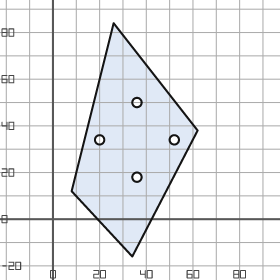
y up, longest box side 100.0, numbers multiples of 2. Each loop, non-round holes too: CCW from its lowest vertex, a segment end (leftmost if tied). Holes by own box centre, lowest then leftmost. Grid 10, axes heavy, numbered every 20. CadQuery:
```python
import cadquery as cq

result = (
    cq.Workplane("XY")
    .moveTo(34.0, -16.0)
    .lineTo(62.0, 38.0)
    .lineTo(26.0, 84.0)
    .lineTo(8.0, 12.0)
    .close()
    .moveTo(36.0, 18.0)
    .circle(2.0)
    .moveTo(20.0, 34.0)
    .circle(2.0)
    .moveTo(52.0, 34.0)
    .circle(2.0)
    .moveTo(36.0, 50.0)
    .circle(2.0)
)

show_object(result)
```